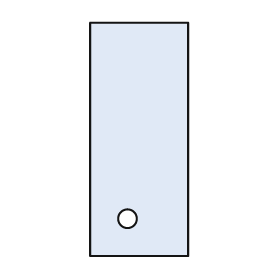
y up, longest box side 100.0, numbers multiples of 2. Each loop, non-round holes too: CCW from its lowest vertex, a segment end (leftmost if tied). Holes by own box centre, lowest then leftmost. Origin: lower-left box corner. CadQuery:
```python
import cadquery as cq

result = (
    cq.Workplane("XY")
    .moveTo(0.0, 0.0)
    .lineTo(42.0, 0.0)
    .lineTo(42.0, 100.0)
    .lineTo(0.0, 100.0)
    .close()
    .moveTo(16.0, 16.0)
    .circle(4.0)
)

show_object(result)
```